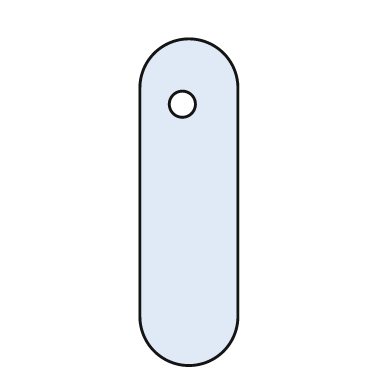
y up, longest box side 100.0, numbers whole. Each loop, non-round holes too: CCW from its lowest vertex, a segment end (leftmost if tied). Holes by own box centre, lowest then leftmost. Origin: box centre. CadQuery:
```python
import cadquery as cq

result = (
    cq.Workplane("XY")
    .moveTo(-15.0, -35.0)
    .threePointArc((0.0, -50.0), (15.0, -35.0))
    .lineTo(15.0, 35.0)
    .threePointArc((0.0, 50.0), (-15.0, 35.0))
    .close()
    .moveTo(-2.0, 30.0)
    .circle(4.0)
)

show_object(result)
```